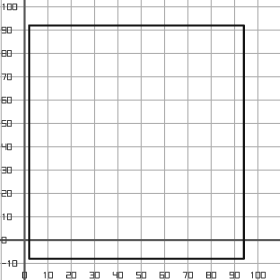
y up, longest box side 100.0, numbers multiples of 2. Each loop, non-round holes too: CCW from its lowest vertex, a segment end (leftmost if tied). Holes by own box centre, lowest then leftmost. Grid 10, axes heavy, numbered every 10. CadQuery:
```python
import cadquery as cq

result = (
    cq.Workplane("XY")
    .moveTo(2.0, -8.0)
    .lineTo(94.0, -8.0)
    .lineTo(94.0, 92.0)
    .lineTo(2.0, 92.0)
    .close()
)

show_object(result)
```